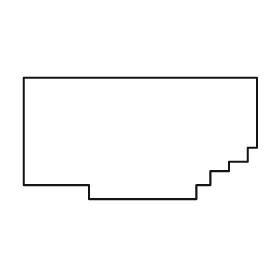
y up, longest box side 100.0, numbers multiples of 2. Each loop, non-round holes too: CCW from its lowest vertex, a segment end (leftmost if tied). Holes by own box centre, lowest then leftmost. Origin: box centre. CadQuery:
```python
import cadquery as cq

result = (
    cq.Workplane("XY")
    .moveTo(-22.0, -26.0)
    .lineTo(24.0, -26.0)
    .lineTo(24.0, -20.0)
    .lineTo(30.0, -20.0)
    .lineTo(30.0, -14.0)
    .lineTo(38.0, -14.0)
    .lineTo(38.0, -10.0)
    .lineTo(46.0, -10.0)
    .lineTo(46.0, -4.0)
    .lineTo(50.0, -4.0)
    .lineTo(50.0, 26.0)
    .lineTo(-50.0, 26.0)
    .lineTo(-50.0, -20.0)
    .lineTo(-22.0, -20.0)
    .close()
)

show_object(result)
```